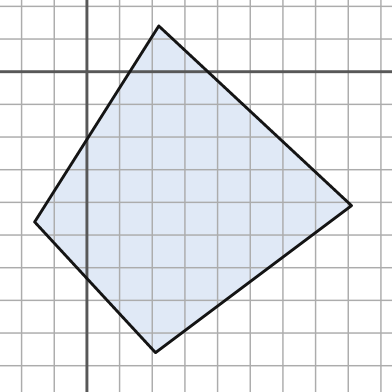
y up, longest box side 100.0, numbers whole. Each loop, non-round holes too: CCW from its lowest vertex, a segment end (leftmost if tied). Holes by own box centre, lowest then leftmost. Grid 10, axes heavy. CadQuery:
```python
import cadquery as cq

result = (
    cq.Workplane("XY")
    .moveTo(21.0, -86.0)
    .lineTo(81.0, -41.0)
    .lineTo(22.0, 14.0)
    .lineTo(-16.0, -46.0)
    .close()
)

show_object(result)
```